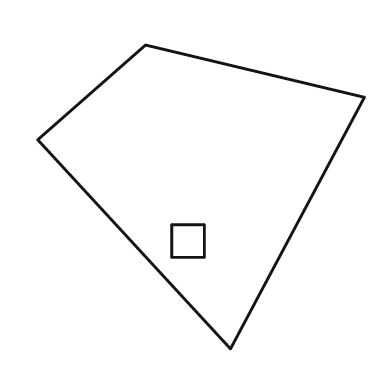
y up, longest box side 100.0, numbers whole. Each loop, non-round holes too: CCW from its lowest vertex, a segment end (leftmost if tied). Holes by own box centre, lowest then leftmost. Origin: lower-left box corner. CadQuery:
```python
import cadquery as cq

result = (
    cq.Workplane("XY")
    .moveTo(59.0, 0.0)
    .lineTo(100.0, 77.0)
    .lineTo(33.0, 93.0)
    .lineTo(0.0, 64.0)
    .close()
    .moveTo(41.0, 28.0)
    .lineTo(51.0, 28.0)
    .lineTo(51.0, 38.0)
    .lineTo(41.0, 38.0)
    .close()
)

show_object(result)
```